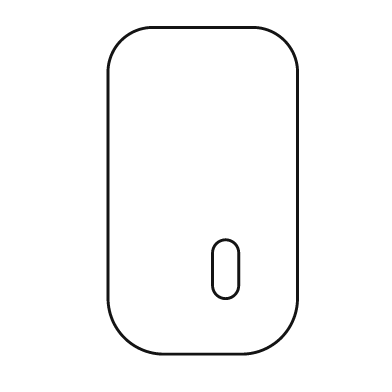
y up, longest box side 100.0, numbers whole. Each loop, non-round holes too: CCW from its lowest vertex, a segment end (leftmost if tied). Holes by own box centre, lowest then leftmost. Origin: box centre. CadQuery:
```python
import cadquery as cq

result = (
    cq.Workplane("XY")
    .moveTo(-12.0, -50.0)
    .lineTo(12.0, -50.0)
    .threePointArc((24.0, -45.0), (29.0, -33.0))
    .lineTo(29.0, 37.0)
    .threePointArc((25.0, 46.0), (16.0, 50.0))
    .lineTo(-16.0, 50.0)
    .threePointArc((-25.0, 46.0), (-29.0, 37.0))
    .lineTo(-29.0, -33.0)
    .threePointArc((-24.0, -45.0), (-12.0, -50.0))
    .close()
    .moveTo(3.0, -29.0)
    .threePointArc((7.0, -33.0), (11.0, -29.0))
    .lineTo(11.0, -19.0)
    .threePointArc((7.0, -15.0), (3.0, -19.0))
    .close()
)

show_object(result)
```